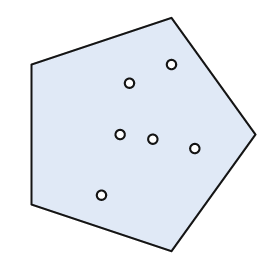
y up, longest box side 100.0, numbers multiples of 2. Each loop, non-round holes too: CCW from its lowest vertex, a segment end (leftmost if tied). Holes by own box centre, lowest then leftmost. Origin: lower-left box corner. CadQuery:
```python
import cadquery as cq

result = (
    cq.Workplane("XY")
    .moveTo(60.0, 0.0)
    .lineTo(96.0, 50.0)
    .lineTo(60.0, 100.0)
    .lineTo(0.0, 80.0)
    .lineTo(0.0, 20.0)
    .close()
    .moveTo(30.0, 24.0)
    .circle(2.0)
    .moveTo(70.0, 44.0)
    .circle(2.0)
    .moveTo(52.0, 48.0)
    .circle(2.0)
    .moveTo(38.0, 50.0)
    .circle(2.0)
    .moveTo(42.0, 72.0)
    .circle(2.0)
    .moveTo(60.0, 80.0)
    .circle(2.0)
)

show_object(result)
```